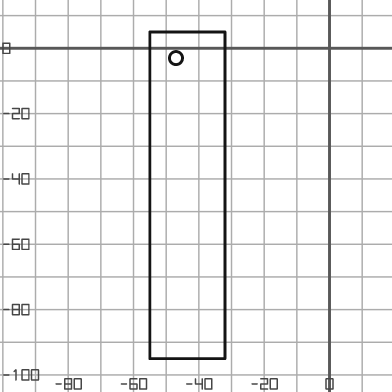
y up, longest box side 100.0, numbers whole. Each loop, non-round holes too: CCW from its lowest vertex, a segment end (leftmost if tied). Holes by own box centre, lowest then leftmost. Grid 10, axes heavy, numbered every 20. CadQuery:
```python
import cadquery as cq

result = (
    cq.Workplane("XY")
    .moveTo(-55.0, -95.0)
    .lineTo(-32.0, -95.0)
    .lineTo(-32.0, 5.0)
    .lineTo(-55.0, 5.0)
    .close()
    .moveTo(-47.0, -3.0)
    .circle(2.0)
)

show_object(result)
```